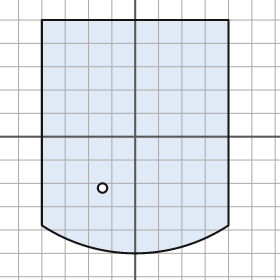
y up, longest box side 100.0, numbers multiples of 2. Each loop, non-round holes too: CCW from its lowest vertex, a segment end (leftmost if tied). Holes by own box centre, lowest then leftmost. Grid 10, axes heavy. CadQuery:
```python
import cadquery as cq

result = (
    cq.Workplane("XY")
    .moveTo(-40.0, -38.0)
    .threePointArc((0.0, -50.0), (40.0, -38.0))
    .lineTo(40.0, 50.0)
    .lineTo(-40.0, 50.0)
    .close()
    .moveTo(-14.0, -22.0)
    .circle(2.0)
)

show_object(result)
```